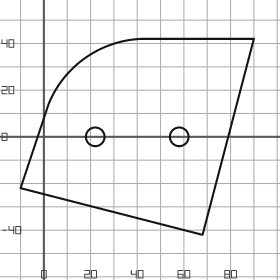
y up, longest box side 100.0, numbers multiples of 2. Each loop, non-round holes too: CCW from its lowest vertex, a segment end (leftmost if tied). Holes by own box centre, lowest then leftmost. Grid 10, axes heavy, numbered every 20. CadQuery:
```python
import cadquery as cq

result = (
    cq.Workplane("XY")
    .moveTo(68.0, -42.0)
    .lineTo(90.0, 42.0)
    .lineTo(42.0, 42.0)
    .threePointArc((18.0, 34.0), (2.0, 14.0))
    .lineTo(-10.0, -22.0)
    .close()
    .moveTo(22.0, 0.0)
    .circle(4.0)
    .moveTo(58.0, 0.0)
    .circle(4.0)
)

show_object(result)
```